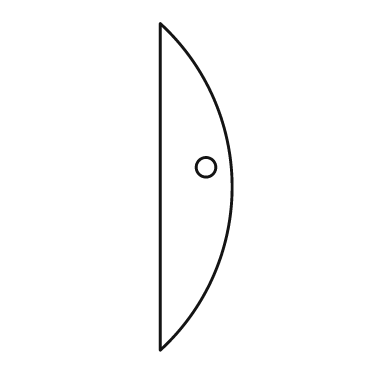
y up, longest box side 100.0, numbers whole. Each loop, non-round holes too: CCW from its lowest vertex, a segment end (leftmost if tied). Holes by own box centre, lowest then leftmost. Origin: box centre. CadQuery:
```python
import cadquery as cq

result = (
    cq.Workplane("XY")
    .moveTo(-11.0, -50.0)
    .threePointArc((11.0, 0.0), (-11.0, 50.0))
    .close()
    .moveTo(3.0, 6.0)
    .circle(3.0)
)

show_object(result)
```